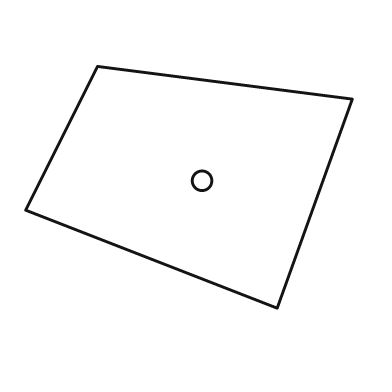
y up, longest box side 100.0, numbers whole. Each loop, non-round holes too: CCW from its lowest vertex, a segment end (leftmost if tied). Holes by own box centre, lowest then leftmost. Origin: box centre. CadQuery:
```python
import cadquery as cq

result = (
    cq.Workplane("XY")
    .moveTo(27.0, -37.0)
    .lineTo(50.0, 27.0)
    .lineTo(-28.0, 37.0)
    .lineTo(-50.0, -7.0)
    .close()
    .moveTo(4.0, 2.0)
    .circle(3.0)
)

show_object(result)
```